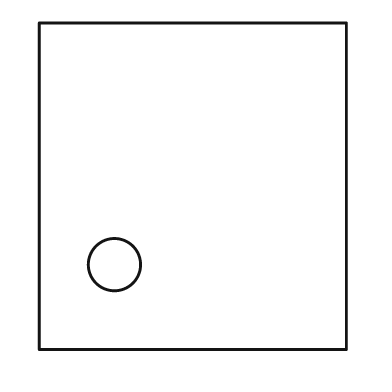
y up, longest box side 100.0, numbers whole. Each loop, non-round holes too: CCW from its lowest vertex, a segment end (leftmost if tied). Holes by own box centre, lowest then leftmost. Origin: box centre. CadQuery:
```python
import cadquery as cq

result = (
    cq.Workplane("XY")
    .moveTo(-47.0, -50.0)
    .lineTo(47.0, -50.0)
    .lineTo(47.0, 50.0)
    .lineTo(-47.0, 50.0)
    .close()
    .moveTo(-24.0, -24.0)
    .circle(8.0)
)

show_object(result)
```